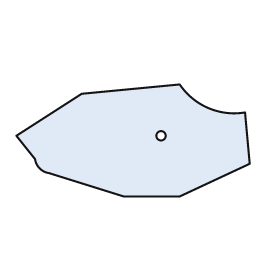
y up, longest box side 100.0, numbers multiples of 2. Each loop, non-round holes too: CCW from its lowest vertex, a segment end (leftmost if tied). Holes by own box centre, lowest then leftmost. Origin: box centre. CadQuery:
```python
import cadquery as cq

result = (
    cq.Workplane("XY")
    .moveTo(-4.0, -24.0)
    .lineTo(20.0, -24.0)
    .lineTo(50.0, -10.0)
    .lineTo(48.0, 12.0)
    .threePointArc((32.0, 14.0), (20.0, 24.0))
    .lineTo(-22.0, 20.0)
    .lineTo(-50.0, 2.0)
    .lineTo(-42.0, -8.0)
    .threePointArc((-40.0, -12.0), (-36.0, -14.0))
    .close()
    .moveTo(12.0, 2.0)
    .circle(2.0)
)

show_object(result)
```